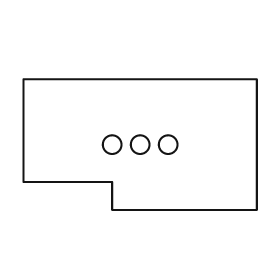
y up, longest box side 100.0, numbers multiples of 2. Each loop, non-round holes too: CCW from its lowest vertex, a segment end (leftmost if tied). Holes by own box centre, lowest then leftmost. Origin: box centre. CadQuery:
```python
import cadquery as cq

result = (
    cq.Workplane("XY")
    .moveTo(-12.0, -28.0)
    .lineTo(50.0, -28.0)
    .lineTo(50.0, 28.0)
    .lineTo(-50.0, 28.0)
    .lineTo(-50.0, -16.0)
    .lineTo(-12.0, -16.0)
    .close()
    .moveTo(-12.0, 0.0)
    .circle(4.0)
    .moveTo(0.0, 0.0)
    .circle(4.0)
    .moveTo(12.0, 0.0)
    .circle(4.0)
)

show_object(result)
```